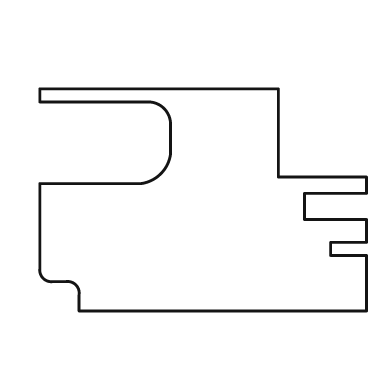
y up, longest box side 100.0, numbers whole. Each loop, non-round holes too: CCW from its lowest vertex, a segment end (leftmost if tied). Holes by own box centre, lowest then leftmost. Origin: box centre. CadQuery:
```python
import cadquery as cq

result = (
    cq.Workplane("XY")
    .moveTo(-38.0, -34.0)
    .lineTo(50.0, -34.0)
    .lineTo(50.0, -17.0)
    .lineTo(39.0, -17.0)
    .lineTo(39.0, -13.0)
    .lineTo(50.0, -13.0)
    .lineTo(50.0, -6.0)
    .lineTo(31.0, -6.0)
    .lineTo(31.0, 2.0)
    .lineTo(50.0, 2.0)
    .lineTo(50.0, 7.0)
    .lineTo(23.0, 7.0)
    .lineTo(23.0, 34.0)
    .lineTo(-50.0, 34.0)
    .lineTo(-50.0, 30.0)
    .lineTo(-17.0, 30.0)
    .threePointArc((-12.0, 28.0), (-10.0, 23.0))
    .lineTo(-10.0, 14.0)
    .threePointArc((-13.0, 8.0), (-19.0, 5.0))
    .lineTo(-50.0, 5.0)
    .lineTo(-50.0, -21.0)
    .threePointArc((-49.0, -24.0), (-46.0, -25.0))
    .lineTo(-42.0, -25.0)
    .threePointArc((-39.0, -26.0), (-38.0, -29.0))
    .close()
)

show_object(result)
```